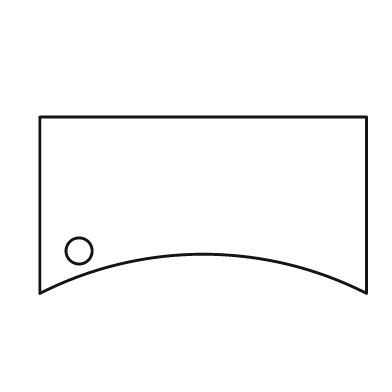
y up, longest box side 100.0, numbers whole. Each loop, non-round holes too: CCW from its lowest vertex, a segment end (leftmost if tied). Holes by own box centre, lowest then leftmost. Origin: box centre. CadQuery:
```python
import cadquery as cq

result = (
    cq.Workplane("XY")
    .moveTo(-50.0, -27.0)
    .threePointArc((0.0, -15.0), (50.0, -27.0))
    .lineTo(50.0, 27.0)
    .lineTo(-50.0, 27.0)
    .close()
    .moveTo(-38.0, -14.0)
    .circle(4.0)
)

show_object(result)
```